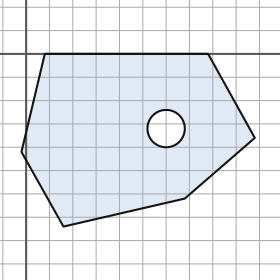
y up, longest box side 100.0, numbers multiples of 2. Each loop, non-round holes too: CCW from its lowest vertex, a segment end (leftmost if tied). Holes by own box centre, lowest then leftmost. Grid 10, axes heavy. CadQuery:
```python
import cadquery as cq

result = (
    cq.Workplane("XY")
    .moveTo(16.0, -74.0)
    .lineTo(68.0, -62.0)
    .lineTo(98.0, -36.0)
    .lineTo(78.0, 0.0)
    .lineTo(8.0, 0.0)
    .lineTo(-2.0, -42.0)
    .close()
    .moveTo(60.0, -32.0)
    .circle(8.0)
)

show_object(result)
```